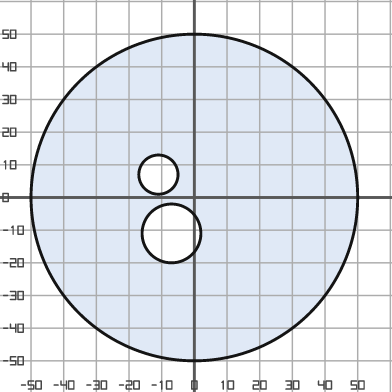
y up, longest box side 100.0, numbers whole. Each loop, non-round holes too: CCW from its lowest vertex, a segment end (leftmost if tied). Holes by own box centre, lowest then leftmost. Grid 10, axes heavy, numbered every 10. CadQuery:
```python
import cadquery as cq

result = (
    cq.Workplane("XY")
    .moveTo(0.0, 0.0)
    .circle(50.0)
    .moveTo(-7.0, -11.0)
    .circle(9.0)
    .moveTo(-11.0, 7.0)
    .circle(6.0)
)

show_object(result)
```